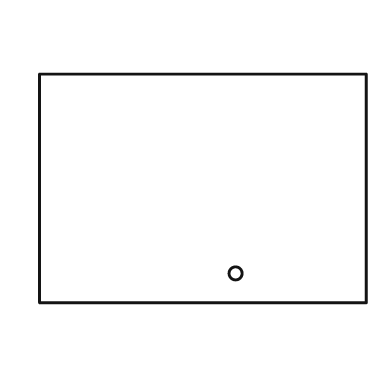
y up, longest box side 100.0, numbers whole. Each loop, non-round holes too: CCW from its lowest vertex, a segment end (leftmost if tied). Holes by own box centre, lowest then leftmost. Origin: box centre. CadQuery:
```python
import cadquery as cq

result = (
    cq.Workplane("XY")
    .moveTo(-50.0, -35.0)
    .lineTo(50.0, -35.0)
    .lineTo(50.0, 35.0)
    .lineTo(-50.0, 35.0)
    .close()
    .moveTo(10.0, -26.0)
    .circle(2.0)
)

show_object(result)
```